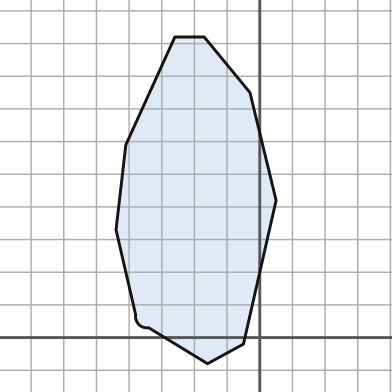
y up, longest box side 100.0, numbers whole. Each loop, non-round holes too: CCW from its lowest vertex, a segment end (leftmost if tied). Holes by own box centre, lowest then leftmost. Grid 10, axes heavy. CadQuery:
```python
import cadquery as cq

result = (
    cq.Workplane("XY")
    .moveTo(-16.0, -8.0)
    .lineTo(-5.0, -2.0)
    .lineTo(5.0, 42.0)
    .lineTo(-3.0, 75.0)
    .lineTo(-17.0, 92.0)
    .lineTo(-26.0, 92.0)
    .lineTo(-41.0, 59.0)
    .lineTo(-44.0, 33.0)
    .lineTo(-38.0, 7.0)
    .threePointArc((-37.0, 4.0), (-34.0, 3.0))
    .close()
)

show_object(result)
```